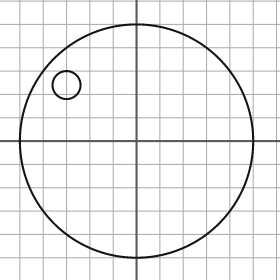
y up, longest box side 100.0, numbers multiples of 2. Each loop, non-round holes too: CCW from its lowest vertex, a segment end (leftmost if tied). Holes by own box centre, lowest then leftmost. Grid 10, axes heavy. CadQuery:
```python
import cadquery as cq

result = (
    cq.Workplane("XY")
    .moveTo(0.0, 0.0)
    .circle(50.0)
    .moveTo(-30.0, 24.0)
    .circle(6.0)
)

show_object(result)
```